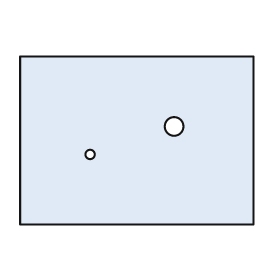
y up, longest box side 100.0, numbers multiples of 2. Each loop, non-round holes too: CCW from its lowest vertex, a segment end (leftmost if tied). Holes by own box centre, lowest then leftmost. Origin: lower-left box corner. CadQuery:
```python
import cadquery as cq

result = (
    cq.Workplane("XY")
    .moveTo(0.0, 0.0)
    .lineTo(100.0, 0.0)
    .lineTo(100.0, 72.0)
    .lineTo(0.0, 72.0)
    .close()
    .moveTo(30.0, 30.0)
    .circle(2.0)
    .moveTo(66.0, 42.0)
    .circle(4.0)
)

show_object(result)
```